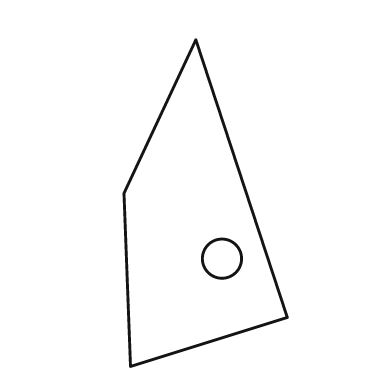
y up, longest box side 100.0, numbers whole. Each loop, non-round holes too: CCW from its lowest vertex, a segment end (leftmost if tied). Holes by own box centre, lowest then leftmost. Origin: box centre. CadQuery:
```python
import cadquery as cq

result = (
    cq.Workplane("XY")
    .moveTo(-23.0, -50.0)
    .lineTo(25.0, -35.0)
    .lineTo(-3.0, 50.0)
    .lineTo(-25.0, 3.0)
    .close()
    .moveTo(5.0, -17.0)
    .circle(6.0)
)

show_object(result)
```